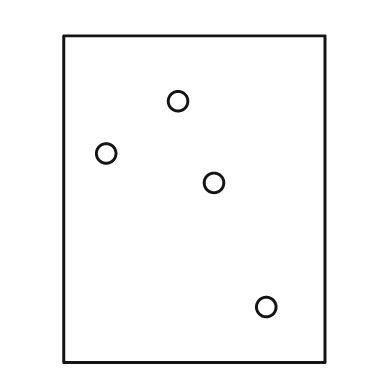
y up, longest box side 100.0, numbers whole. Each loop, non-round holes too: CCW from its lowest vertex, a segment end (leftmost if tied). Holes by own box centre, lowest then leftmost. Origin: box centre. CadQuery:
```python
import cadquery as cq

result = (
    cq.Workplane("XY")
    .moveTo(-40.0, -50.0)
    .lineTo(40.0, -50.0)
    .lineTo(40.0, 50.0)
    .lineTo(-40.0, 50.0)
    .close()
    .moveTo(22.0, -33.0)
    .circle(3.0)
    .moveTo(6.0, 5.0)
    .circle(3.0)
    .moveTo(-27.0, 14.0)
    .circle(3.0)
    .moveTo(-5.0, 30.0)
    .circle(3.0)
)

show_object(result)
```